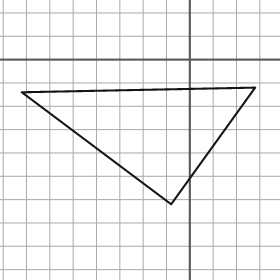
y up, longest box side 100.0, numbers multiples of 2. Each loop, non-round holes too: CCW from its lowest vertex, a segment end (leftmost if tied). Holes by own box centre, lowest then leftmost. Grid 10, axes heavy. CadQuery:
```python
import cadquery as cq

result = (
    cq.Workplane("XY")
    .moveTo(-8.0, -62.0)
    .lineTo(28.0, -12.0)
    .lineTo(-72.0, -14.0)
    .close()
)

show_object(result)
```